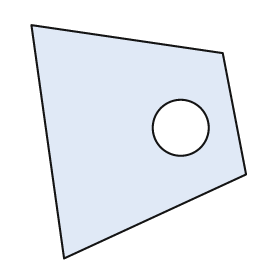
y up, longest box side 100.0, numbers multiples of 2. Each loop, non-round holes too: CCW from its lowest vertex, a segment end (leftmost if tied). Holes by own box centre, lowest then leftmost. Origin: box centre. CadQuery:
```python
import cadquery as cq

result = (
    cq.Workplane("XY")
    .moveTo(-32.0, -50.0)
    .lineTo(46.0, -14.0)
    .lineTo(36.0, 38.0)
    .lineTo(-46.0, 50.0)
    .close()
    .moveTo(18.0, 6.0)
    .circle(12.0)
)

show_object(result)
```